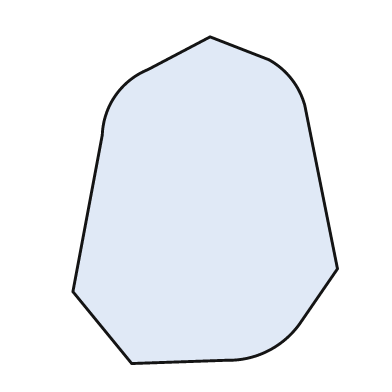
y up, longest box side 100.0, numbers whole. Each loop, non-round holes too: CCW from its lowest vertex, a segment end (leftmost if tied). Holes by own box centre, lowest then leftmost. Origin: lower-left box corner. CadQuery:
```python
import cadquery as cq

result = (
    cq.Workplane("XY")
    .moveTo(18.0, 0.0)
    .lineTo(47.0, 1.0)
    .threePointArc((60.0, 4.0), (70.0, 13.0))
    .lineTo(81.0, 29.0)
    .lineTo(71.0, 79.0)
    .threePointArc((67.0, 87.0), (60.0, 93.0))
    .lineTo(42.0, 100.0)
    .lineTo(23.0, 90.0)
    .threePointArc((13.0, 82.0), (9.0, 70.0))
    .lineTo(0.0, 22.0)
    .close()
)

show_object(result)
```